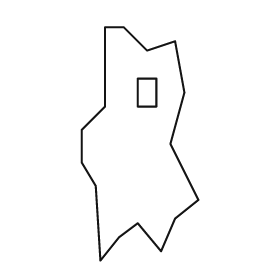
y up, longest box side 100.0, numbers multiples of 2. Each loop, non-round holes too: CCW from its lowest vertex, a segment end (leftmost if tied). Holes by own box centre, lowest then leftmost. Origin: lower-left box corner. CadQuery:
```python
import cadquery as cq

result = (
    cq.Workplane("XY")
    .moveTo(8.0, 0.0)
    .lineTo(16.0, 10.0)
    .lineTo(24.0, 16.0)
    .lineTo(34.0, 4.0)
    .lineTo(40.0, 18.0)
    .lineTo(50.0, 26.0)
    .lineTo(38.0, 50.0)
    .lineTo(44.0, 72.0)
    .lineTo(40.0, 94.0)
    .lineTo(28.0, 90.0)
    .lineTo(18.0, 100.0)
    .lineTo(10.0, 100.0)
    .lineTo(10.0, 66.0)
    .lineTo(0.0, 56.0)
    .lineTo(0.0, 42.0)
    .lineTo(6.0, 32.0)
    .close()
    .moveTo(24.0, 66.0)
    .lineTo(32.0, 66.0)
    .lineTo(32.0, 78.0)
    .lineTo(24.0, 78.0)
    .close()
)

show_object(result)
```